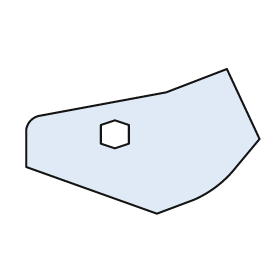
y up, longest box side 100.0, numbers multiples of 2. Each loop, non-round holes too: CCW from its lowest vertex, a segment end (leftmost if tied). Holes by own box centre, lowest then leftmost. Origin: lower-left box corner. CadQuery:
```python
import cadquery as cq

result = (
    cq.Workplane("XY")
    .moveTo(56.0, 0.0)
    .lineTo(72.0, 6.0)
    .threePointArc((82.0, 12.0), (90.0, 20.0))
    .lineTo(100.0, 32.0)
    .lineTo(86.0, 62.0)
    .lineTo(60.0, 52.0)
    .lineTo(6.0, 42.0)
    .threePointArc((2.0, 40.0), (0.0, 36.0))
    .lineTo(0.0, 20.0)
    .close()
    .moveTo(38.0, 28.0)
    .lineTo(44.0, 30.0)
    .lineTo(44.0, 38.0)
    .lineTo(38.0, 40.0)
    .lineTo(32.0, 38.0)
    .lineTo(32.0, 30.0)
    .close()
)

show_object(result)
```